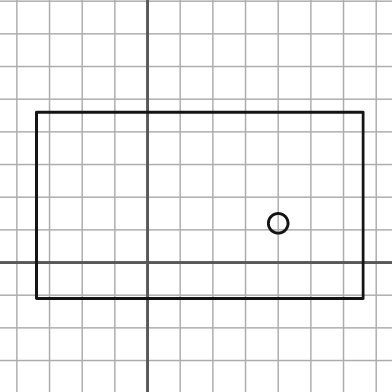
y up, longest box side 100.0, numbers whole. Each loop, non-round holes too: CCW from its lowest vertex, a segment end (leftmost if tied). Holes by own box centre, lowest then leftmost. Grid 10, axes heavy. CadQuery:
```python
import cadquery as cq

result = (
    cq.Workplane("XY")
    .moveTo(-34.0, -11.0)
    .lineTo(66.0, -11.0)
    .lineTo(66.0, 46.0)
    .lineTo(-34.0, 46.0)
    .close()
    .moveTo(40.0, 12.0)
    .circle(3.0)
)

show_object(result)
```